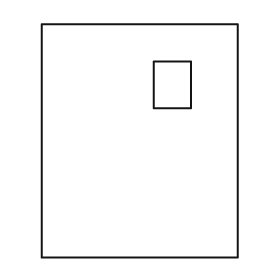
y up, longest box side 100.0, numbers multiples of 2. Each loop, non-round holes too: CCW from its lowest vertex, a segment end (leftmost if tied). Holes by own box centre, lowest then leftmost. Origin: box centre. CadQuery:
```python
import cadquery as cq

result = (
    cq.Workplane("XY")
    .moveTo(-42.0, -50.0)
    .lineTo(42.0, -50.0)
    .lineTo(42.0, 50.0)
    .lineTo(-42.0, 50.0)
    .close()
    .moveTo(6.0, 14.0)
    .lineTo(22.0, 14.0)
    .lineTo(22.0, 34.0)
    .lineTo(6.0, 34.0)
    .close()
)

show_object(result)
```